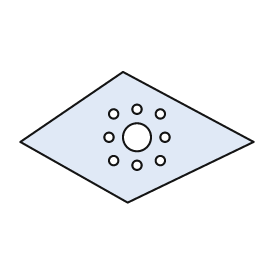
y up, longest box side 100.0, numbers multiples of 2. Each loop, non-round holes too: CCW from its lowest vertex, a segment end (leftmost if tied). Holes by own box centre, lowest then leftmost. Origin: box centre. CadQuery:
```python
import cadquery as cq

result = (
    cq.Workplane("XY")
    .moveTo(-4.0, -28.0)
    .lineTo(50.0, -2.0)
    .lineTo(-6.0, 28.0)
    .lineTo(-50.0, -2.0)
    .close()
    .moveTo(0.0, -12.0)
    .circle(2.0)
    .moveTo(-10.0, -10.0)
    .circle(2.0)
    .moveTo(10.0, -10.0)
    .circle(2.0)
    .moveTo(-12.0, 0.0)
    .circle(2.0)
    .moveTo(0.0, 0.0)
    .circle(6.0)
    .moveTo(12.0, 0.0)
    .circle(2.0)
    .moveTo(-10.0, 10.0)
    .circle(2.0)
    .moveTo(10.0, 10.0)
    .circle(2.0)
    .moveTo(0.0, 12.0)
    .circle(2.0)
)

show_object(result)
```